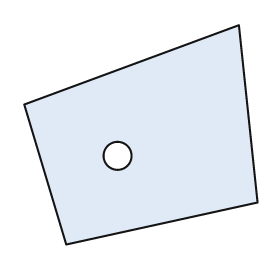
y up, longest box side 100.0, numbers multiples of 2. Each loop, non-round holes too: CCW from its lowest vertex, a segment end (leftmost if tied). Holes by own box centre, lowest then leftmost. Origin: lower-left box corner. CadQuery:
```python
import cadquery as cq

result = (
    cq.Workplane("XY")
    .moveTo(18.0, 0.0)
    .lineTo(100.0, 18.0)
    .lineTo(92.0, 94.0)
    .lineTo(0.0, 60.0)
    .close()
    .moveTo(40.0, 38.0)
    .circle(6.0)
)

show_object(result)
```